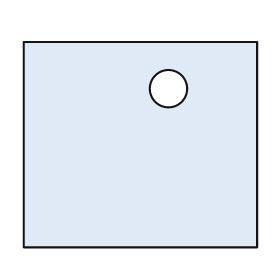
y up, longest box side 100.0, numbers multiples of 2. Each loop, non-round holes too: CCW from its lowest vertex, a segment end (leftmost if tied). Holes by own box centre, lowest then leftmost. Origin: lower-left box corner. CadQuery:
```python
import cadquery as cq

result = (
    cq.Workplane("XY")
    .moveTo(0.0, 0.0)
    .lineTo(100.0, 0.0)
    .lineTo(100.0, 88.0)
    .lineTo(0.0, 88.0)
    .close()
    .moveTo(62.0, 68.0)
    .circle(8.0)
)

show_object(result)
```